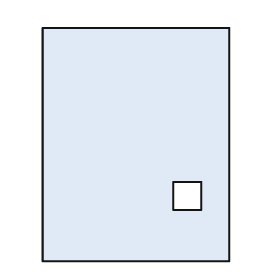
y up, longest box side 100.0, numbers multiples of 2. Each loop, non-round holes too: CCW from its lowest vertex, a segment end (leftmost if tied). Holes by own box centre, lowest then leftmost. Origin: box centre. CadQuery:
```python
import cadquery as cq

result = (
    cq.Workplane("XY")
    .moveTo(-40.0, -50.0)
    .lineTo(40.0, -50.0)
    .lineTo(40.0, 50.0)
    .lineTo(-40.0, 50.0)
    .close()
    .moveTo(16.0, -28.0)
    .lineTo(28.0, -28.0)
    .lineTo(28.0, -16.0)
    .lineTo(16.0, -16.0)
    .close()
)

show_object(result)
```